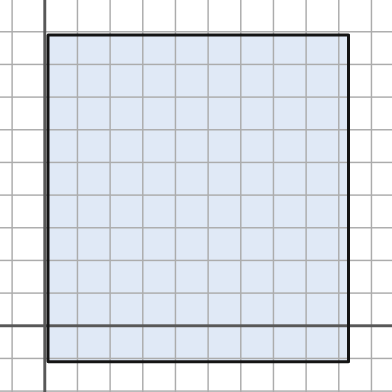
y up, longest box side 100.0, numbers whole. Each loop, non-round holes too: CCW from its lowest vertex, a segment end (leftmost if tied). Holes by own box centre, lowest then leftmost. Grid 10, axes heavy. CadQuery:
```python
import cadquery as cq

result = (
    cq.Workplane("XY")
    .moveTo(1.0, -11.0)
    .lineTo(93.0, -11.0)
    .lineTo(93.0, 89.0)
    .lineTo(1.0, 89.0)
    .close()
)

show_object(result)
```